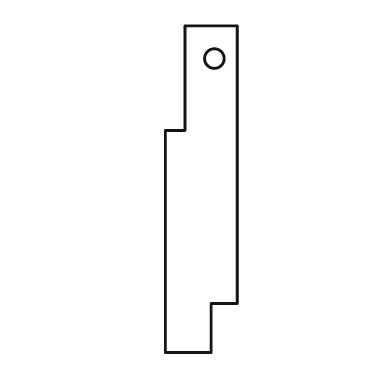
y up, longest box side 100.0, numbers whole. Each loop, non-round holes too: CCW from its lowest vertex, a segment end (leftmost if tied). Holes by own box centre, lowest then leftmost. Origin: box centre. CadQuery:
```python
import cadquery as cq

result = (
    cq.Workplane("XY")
    .moveTo(-11.0, -50.0)
    .lineTo(3.0, -50.0)
    .lineTo(3.0, -35.0)
    .lineTo(11.0, -35.0)
    .lineTo(11.0, 50.0)
    .lineTo(-5.0, 50.0)
    .lineTo(-5.0, 18.0)
    .lineTo(-11.0, 18.0)
    .close()
    .moveTo(4.0, 40.0)
    .circle(3.0)
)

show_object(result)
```